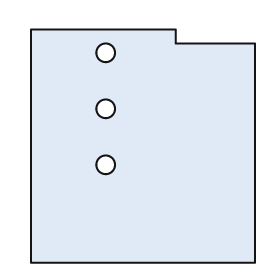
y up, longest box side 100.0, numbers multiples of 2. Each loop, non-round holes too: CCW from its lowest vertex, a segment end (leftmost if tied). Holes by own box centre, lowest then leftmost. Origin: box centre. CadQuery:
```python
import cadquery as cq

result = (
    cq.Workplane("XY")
    .moveTo(-48.0, -50.0)
    .lineTo(48.0, -50.0)
    .lineTo(48.0, 44.0)
    .lineTo(14.0, 44.0)
    .lineTo(14.0, 50.0)
    .lineTo(-48.0, 50.0)
    .close()
    .moveTo(-16.0, -8.0)
    .circle(4.0)
    .moveTo(-16.0, 16.0)
    .circle(4.0)
    .moveTo(-16.0, 40.0)
    .circle(4.0)
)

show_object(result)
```